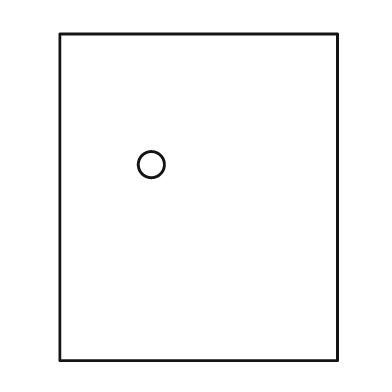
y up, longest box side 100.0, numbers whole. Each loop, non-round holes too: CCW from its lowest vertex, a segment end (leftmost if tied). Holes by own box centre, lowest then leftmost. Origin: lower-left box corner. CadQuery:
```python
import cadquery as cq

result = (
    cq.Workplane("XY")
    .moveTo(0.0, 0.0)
    .lineTo(85.0, 0.0)
    .lineTo(85.0, 100.0)
    .lineTo(0.0, 100.0)
    .close()
    .moveTo(28.0, 60.0)
    .circle(4.0)
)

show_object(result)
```